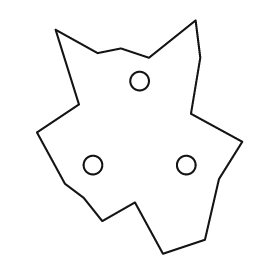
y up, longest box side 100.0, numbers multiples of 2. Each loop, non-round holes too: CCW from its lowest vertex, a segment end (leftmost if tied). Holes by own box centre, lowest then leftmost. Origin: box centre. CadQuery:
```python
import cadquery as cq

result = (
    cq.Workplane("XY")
    .moveTo(10.0, -50.0)
    .lineTo(28.0, -44.0)
    .lineTo(34.0, -18.0)
    .lineTo(44.0, -2.0)
    .lineTo(22.0, 10.0)
    .lineTo(26.0, 34.0)
    .lineTo(24.0, 50.0)
    .lineTo(4.0, 34.0)
    .lineTo(-8.0, 38.0)
    .lineTo(-18.0, 36.0)
    .lineTo(-36.0, 46.0)
    .lineTo(-26.0, 14.0)
    .lineTo(-44.0, 2.0)
    .lineTo(-32.0, -20.0)
    .lineTo(-24.0, -26.0)
    .lineTo(-16.0, -36.0)
    .lineTo(-2.0, -28.0)
    .close()
    .moveTo(-20.0, -12.0)
    .circle(4.0)
    .moveTo(20.0, -12.0)
    .circle(4.0)
    .moveTo(0.0, 24.0)
    .circle(4.0)
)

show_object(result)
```